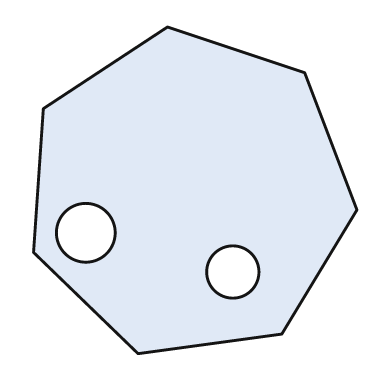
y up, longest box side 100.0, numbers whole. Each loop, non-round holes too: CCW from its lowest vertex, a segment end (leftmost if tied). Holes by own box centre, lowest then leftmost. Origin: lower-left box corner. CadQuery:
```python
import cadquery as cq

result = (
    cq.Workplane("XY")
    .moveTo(32.0, 0.0)
    .lineTo(76.0, 6.0)
    .lineTo(99.0, 44.0)
    .lineTo(83.0, 86.0)
    .lineTo(41.0, 100.0)
    .lineTo(3.0, 75.0)
    .lineTo(0.0, 31.0)
    .close()
    .moveTo(61.0, 25.0)
    .circle(8.0)
    .moveTo(16.0, 37.0)
    .circle(9.0)
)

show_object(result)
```